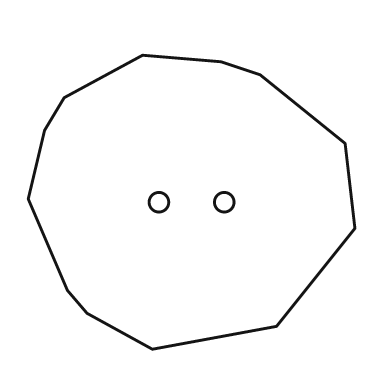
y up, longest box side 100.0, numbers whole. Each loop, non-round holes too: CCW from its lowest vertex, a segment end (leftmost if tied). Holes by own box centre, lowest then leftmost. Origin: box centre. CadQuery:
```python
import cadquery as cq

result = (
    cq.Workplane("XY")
    .moveTo(-12.0, -45.0)
    .lineTo(26.0, -38.0)
    .lineTo(50.0, -8.0)
    .lineTo(47.0, 18.0)
    .lineTo(21.0, 39.0)
    .lineTo(9.0, 43.0)
    .lineTo(-15.0, 45.0)
    .lineTo(-39.0, 32.0)
    .lineTo(-45.0, 22.0)
    .lineTo(-50.0, 1.0)
    .lineTo(-38.0, -27.0)
    .lineTo(-32.0, -34.0)
    .close()
    .moveTo(-10.0, 0.0)
    .circle(3.0)
    .moveTo(10.0, 0.0)
    .circle(3.0)
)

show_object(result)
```